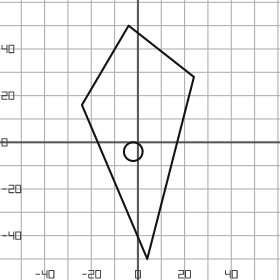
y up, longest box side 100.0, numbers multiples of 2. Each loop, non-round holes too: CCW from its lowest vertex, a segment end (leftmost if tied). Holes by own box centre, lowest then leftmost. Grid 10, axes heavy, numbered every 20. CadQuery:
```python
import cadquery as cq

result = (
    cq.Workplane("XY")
    .moveTo(4.0, -50.0)
    .lineTo(24.0, 28.0)
    .lineTo(-4.0, 50.0)
    .lineTo(-24.0, 16.0)
    .close()
    .moveTo(-2.0, -4.0)
    .circle(4.0)
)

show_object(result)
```